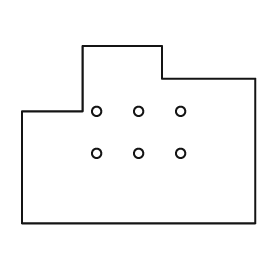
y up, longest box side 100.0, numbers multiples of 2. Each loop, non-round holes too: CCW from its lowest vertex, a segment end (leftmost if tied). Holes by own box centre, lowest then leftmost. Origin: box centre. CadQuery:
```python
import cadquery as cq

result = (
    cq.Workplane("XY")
    .moveTo(-50.0, -38.0)
    .lineTo(50.0, -38.0)
    .lineTo(50.0, 24.0)
    .lineTo(10.0, 24.0)
    .lineTo(10.0, 38.0)
    .lineTo(-24.0, 38.0)
    .lineTo(-24.0, 10.0)
    .lineTo(-50.0, 10.0)
    .close()
    .moveTo(-18.0, -8.0)
    .circle(2.0)
    .moveTo(0.0, -8.0)
    .circle(2.0)
    .moveTo(18.0, -8.0)
    .circle(2.0)
    .moveTo(-18.0, 10.0)
    .circle(2.0)
    .moveTo(0.0, 10.0)
    .circle(2.0)
    .moveTo(18.0, 10.0)
    .circle(2.0)
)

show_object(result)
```